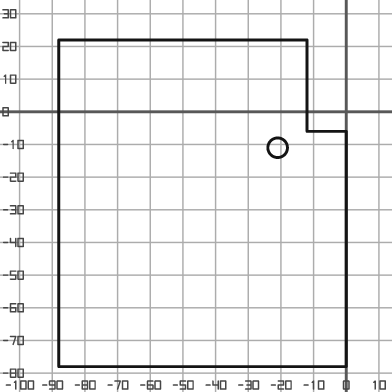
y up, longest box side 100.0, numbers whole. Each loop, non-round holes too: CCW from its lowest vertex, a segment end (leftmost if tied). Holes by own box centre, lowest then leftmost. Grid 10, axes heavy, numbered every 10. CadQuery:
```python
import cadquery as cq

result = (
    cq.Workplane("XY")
    .moveTo(-88.0, -78.0)
    .lineTo(0.0, -78.0)
    .lineTo(0.0, -6.0)
    .lineTo(-12.0, -6.0)
    .lineTo(-12.0, 22.0)
    .lineTo(-88.0, 22.0)
    .close()
    .moveTo(-21.0, -11.0)
    .circle(3.0)
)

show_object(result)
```